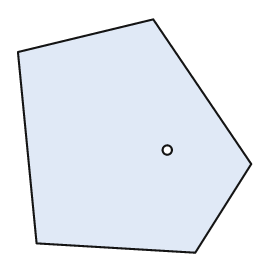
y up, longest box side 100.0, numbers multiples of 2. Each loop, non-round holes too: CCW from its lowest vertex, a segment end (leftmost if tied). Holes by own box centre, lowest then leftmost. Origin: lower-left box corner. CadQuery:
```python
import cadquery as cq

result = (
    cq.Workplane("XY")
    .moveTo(76.0, 0.0)
    .lineTo(100.0, 38.0)
    .lineTo(58.0, 100.0)
    .lineTo(0.0, 86.0)
    .lineTo(8.0, 4.0)
    .close()
    .moveTo(64.0, 44.0)
    .circle(2.0)
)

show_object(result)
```